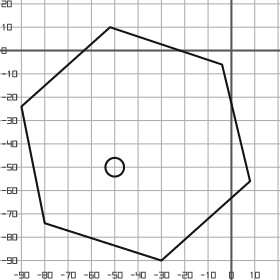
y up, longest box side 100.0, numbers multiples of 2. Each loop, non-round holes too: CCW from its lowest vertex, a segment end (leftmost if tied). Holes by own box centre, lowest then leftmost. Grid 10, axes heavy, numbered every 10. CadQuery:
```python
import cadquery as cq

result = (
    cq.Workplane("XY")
    .moveTo(-30.0, -90.0)
    .lineTo(8.0, -56.0)
    .lineTo(-4.0, -6.0)
    .lineTo(-52.0, 10.0)
    .lineTo(-90.0, -24.0)
    .lineTo(-80.0, -74.0)
    .close()
    .moveTo(-50.0, -50.0)
    .circle(4.0)
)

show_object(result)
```